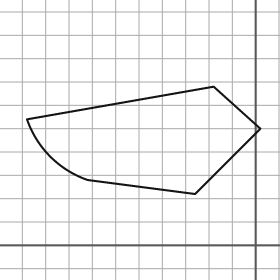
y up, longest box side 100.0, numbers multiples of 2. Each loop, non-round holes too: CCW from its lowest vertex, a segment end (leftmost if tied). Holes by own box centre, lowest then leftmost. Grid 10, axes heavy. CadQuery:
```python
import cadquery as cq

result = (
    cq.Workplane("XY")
    .moveTo(-26.0, 22.0)
    .lineTo(2.0, 50.0)
    .lineTo(-18.0, 68.0)
    .lineTo(-98.0, 54.0)
    .threePointArc((-88.0, 38.0), (-72.0, 28.0))
    .close()
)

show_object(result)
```